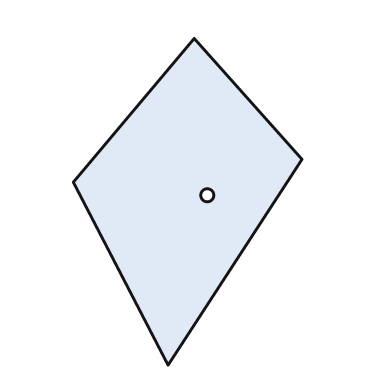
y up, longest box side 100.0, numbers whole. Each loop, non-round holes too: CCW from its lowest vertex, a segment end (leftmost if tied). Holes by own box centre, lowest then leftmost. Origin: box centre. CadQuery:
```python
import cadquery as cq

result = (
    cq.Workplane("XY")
    .moveTo(-6.0, -50.0)
    .lineTo(35.0, 13.0)
    .lineTo(2.0, 50.0)
    .lineTo(-35.0, 6.0)
    .close()
    .moveTo(6.0, 2.0)
    .circle(2.0)
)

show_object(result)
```